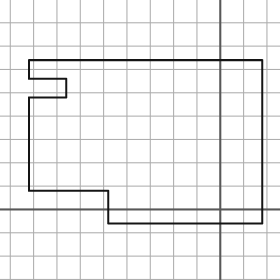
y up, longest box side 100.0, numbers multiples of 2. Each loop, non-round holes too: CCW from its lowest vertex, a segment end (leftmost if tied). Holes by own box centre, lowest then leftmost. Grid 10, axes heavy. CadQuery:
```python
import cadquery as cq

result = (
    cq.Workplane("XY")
    .moveTo(-48.0, -6.0)
    .lineTo(18.0, -6.0)
    .lineTo(18.0, 64.0)
    .lineTo(-82.0, 64.0)
    .lineTo(-82.0, 56.0)
    .lineTo(-66.0, 56.0)
    .lineTo(-66.0, 48.0)
    .lineTo(-82.0, 48.0)
    .lineTo(-82.0, 8.0)
    .lineTo(-48.0, 8.0)
    .close()
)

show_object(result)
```